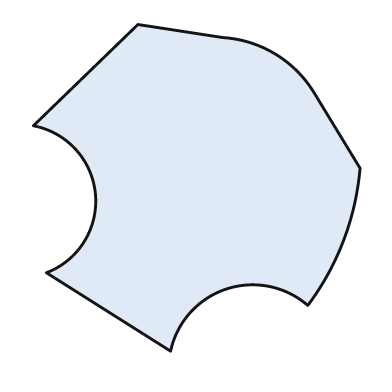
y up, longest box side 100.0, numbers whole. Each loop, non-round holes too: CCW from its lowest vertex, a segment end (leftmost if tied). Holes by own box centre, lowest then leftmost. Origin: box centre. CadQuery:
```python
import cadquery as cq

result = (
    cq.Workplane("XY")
    .moveTo(-8.0, -50.0)
    .threePointArc((9.0, -31.0), (34.0, -36.0))
    .threePointArc((45.0, -16.0), (50.0, 6.0))
    .lineTo(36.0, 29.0)
    .threePointArc((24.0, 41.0), (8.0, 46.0))
    .lineTo(-18.0, 50.0)
    .lineTo(-50.0, 19.0)
    .threePointArc((-31.0, -2.0), (-46.0, -26.0))
    .close()
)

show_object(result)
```